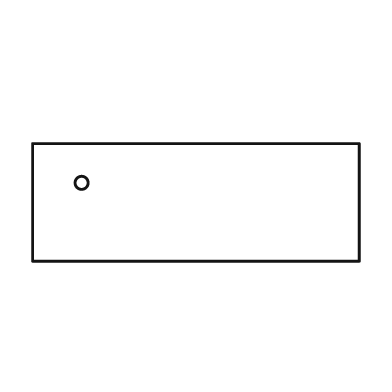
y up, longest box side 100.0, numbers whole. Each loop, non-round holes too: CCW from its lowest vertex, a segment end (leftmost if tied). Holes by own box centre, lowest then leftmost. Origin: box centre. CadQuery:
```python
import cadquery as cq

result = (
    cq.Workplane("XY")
    .moveTo(-50.0, -18.0)
    .lineTo(50.0, -18.0)
    .lineTo(50.0, 18.0)
    .lineTo(-50.0, 18.0)
    .close()
    .moveTo(-35.0, 6.0)
    .circle(2.0)
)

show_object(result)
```